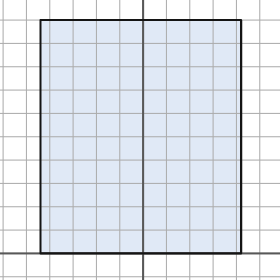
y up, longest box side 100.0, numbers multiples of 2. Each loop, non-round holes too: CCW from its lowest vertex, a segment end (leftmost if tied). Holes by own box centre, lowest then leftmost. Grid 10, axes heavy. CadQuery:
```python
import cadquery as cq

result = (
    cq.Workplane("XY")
    .moveTo(-44.0, 0.0)
    .lineTo(42.0, 0.0)
    .lineTo(42.0, 100.0)
    .lineTo(-44.0, 100.0)
    .close()
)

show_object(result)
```